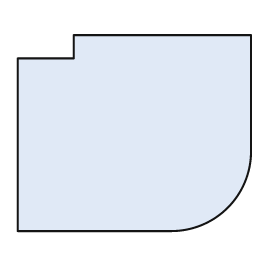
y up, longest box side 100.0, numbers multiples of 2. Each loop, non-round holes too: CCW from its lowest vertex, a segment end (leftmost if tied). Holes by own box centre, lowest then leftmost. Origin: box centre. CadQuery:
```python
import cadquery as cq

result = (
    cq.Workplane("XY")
    .moveTo(-50.0, -42.0)
    .lineTo(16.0, -42.0)
    .threePointArc((40.0, -32.0), (50.0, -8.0))
    .lineTo(50.0, 42.0)
    .lineTo(-26.0, 42.0)
    .lineTo(-26.0, 32.0)
    .lineTo(-50.0, 32.0)
    .close()
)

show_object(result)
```